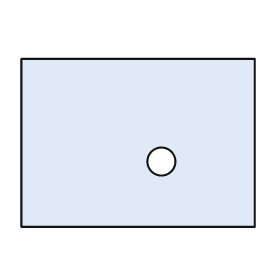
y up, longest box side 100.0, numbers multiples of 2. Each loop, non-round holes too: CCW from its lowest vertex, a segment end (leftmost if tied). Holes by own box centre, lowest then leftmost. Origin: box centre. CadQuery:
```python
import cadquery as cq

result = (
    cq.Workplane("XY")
    .moveTo(-50.0, -36.0)
    .lineTo(50.0, -36.0)
    .lineTo(50.0, 36.0)
    .lineTo(-50.0, 36.0)
    .close()
    .moveTo(10.0, -8.0)
    .circle(6.0)
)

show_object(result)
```